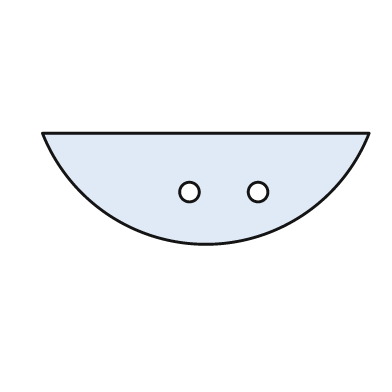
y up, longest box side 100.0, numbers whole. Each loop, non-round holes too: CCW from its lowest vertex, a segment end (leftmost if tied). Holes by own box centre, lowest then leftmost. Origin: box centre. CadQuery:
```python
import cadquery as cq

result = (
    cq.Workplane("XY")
    .moveTo(-50.0, 17.0)
    .threePointArc((0.0, -17.0), (50.0, 17.0))
    .close()
    .moveTo(-5.0, -1.0)
    .circle(3.0)
    .moveTo(16.0, -1.0)
    .circle(3.0)
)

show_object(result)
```